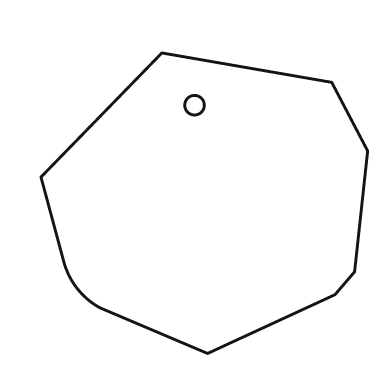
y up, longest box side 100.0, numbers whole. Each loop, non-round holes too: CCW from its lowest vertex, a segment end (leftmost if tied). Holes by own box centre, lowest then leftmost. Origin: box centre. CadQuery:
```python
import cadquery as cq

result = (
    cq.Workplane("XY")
    .moveTo(1.0, -46.0)
    .lineTo(40.0, -28.0)
    .lineTo(46.0, -21.0)
    .lineTo(50.0, 16.0)
    .lineTo(39.0, 37.0)
    .lineTo(-13.0, 46.0)
    .lineTo(-50.0, 8.0)
    .lineTo(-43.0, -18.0)
    .threePointArc((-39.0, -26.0), (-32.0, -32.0))
    .close()
    .moveTo(-3.0, 30.0)
    .circle(3.0)
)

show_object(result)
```